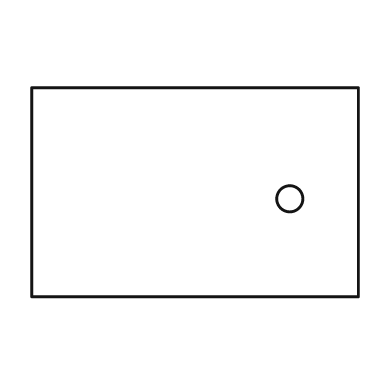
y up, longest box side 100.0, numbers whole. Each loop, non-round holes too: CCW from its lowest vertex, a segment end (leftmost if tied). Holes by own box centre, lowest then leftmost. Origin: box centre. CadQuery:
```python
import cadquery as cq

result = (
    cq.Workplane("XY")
    .moveTo(-50.0, -32.0)
    .lineTo(50.0, -32.0)
    .lineTo(50.0, 32.0)
    .lineTo(-50.0, 32.0)
    .close()
    .moveTo(29.0, -2.0)
    .circle(4.0)
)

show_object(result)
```